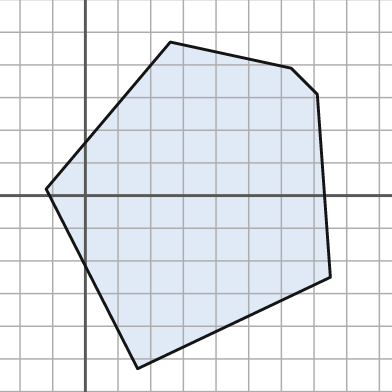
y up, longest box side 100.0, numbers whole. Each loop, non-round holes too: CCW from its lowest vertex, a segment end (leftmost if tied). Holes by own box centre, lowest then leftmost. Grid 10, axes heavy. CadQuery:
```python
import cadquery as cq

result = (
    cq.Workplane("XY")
    .moveTo(16.0, -53.0)
    .lineTo(75.0, -25.0)
    .lineTo(71.0, 31.0)
    .lineTo(63.0, 39.0)
    .lineTo(26.0, 47.0)
    .lineTo(-12.0, 2.0)
    .close()
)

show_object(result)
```